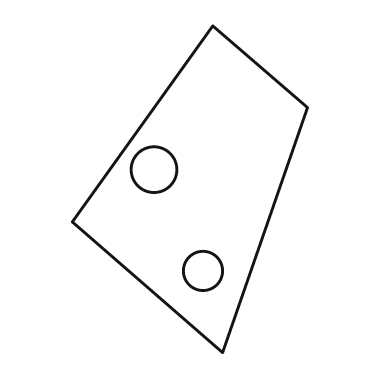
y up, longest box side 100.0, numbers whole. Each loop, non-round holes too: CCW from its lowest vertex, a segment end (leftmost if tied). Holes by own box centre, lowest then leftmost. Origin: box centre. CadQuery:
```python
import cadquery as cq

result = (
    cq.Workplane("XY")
    .moveTo(10.0, -50.0)
    .lineTo(36.0, 25.0)
    .lineTo(7.0, 50.0)
    .lineTo(-36.0, -10.0)
    .close()
    .moveTo(4.0, -25.0)
    .circle(6.0)
    .moveTo(-11.0, 6.0)
    .circle(7.0)
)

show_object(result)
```